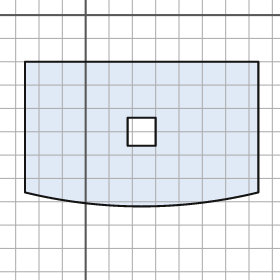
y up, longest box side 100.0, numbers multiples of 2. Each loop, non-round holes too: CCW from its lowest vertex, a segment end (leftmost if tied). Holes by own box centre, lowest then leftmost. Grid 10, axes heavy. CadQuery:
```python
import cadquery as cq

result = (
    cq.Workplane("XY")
    .moveTo(-26.0, -76.0)
    .threePointArc((24.0, -82.0), (74.0, -76.0))
    .lineTo(74.0, -20.0)
    .lineTo(-26.0, -20.0)
    .close()
    .moveTo(18.0, -56.0)
    .lineTo(30.0, -56.0)
    .lineTo(30.0, -44.0)
    .lineTo(18.0, -44.0)
    .close()
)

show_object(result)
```